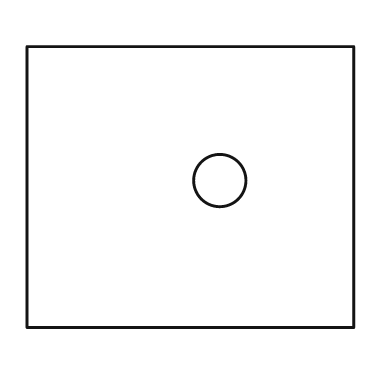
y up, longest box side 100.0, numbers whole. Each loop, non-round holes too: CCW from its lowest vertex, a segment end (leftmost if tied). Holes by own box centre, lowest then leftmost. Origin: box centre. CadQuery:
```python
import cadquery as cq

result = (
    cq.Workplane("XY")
    .moveTo(-50.0, -43.0)
    .lineTo(50.0, -43.0)
    .lineTo(50.0, 43.0)
    .lineTo(-50.0, 43.0)
    .close()
    .moveTo(9.0, 2.0)
    .circle(8.0)
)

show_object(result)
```